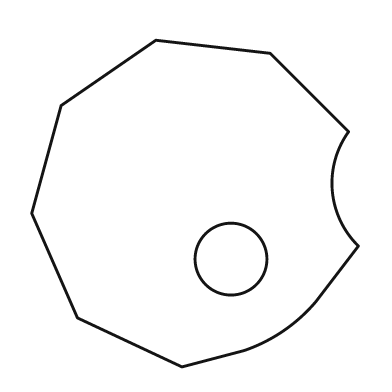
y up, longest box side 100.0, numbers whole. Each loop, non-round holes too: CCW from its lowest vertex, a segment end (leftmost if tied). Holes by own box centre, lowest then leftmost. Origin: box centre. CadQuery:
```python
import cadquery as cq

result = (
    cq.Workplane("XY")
    .moveTo(-4.0, -50.0)
    .lineTo(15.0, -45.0)
    .threePointArc((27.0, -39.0), (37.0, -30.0))
    .lineTo(50.0, -13.0)
    .threePointArc((42.0, 4.0), (47.0, 22.0))
    .lineTo(23.0, 46.0)
    .lineTo(-12.0, 50.0)
    .lineTo(-41.0, 30.0)
    .lineTo(-50.0, -3.0)
    .lineTo(-36.0, -35.0)
    .close()
    .moveTo(11.0, -17.0)
    .circle(11.0)
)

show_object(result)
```